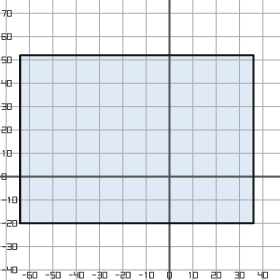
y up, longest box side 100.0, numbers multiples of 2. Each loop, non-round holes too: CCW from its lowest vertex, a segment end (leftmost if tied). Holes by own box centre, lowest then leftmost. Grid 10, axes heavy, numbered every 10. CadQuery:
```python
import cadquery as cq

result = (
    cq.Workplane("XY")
    .moveTo(-64.0, -20.0)
    .lineTo(36.0, -20.0)
    .lineTo(36.0, 52.0)
    .lineTo(-64.0, 52.0)
    .close()
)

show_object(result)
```